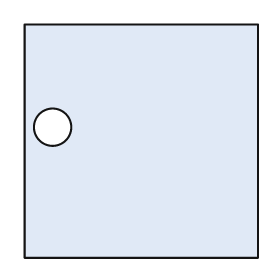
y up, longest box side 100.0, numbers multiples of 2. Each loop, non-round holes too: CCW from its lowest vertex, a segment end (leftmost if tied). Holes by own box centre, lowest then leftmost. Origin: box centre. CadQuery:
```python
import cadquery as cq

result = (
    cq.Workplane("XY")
    .moveTo(-50.0, -50.0)
    .lineTo(50.0, -50.0)
    .lineTo(50.0, 50.0)
    .lineTo(-50.0, 50.0)
    .close()
    .moveTo(-38.0, 6.0)
    .circle(8.0)
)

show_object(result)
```